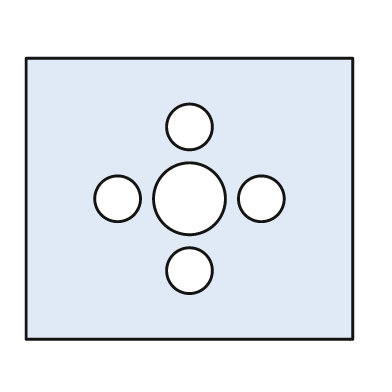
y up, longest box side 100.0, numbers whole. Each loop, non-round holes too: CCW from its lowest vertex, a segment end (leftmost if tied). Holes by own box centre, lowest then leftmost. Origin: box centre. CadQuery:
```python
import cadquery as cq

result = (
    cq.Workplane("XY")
    .moveTo(-50.0, -43.0)
    .lineTo(50.0, -43.0)
    .lineTo(50.0, 43.0)
    .lineTo(-50.0, 43.0)
    .close()
    .moveTo(0.0, -22.0)
    .circle(7.0)
    .moveTo(-22.0, 0.0)
    .circle(7.0)
    .moveTo(0.0, 0.0)
    .circle(11.0)
    .moveTo(22.0, 0.0)
    .circle(7.0)
    .moveTo(0.0, 22.0)
    .circle(7.0)
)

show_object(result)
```